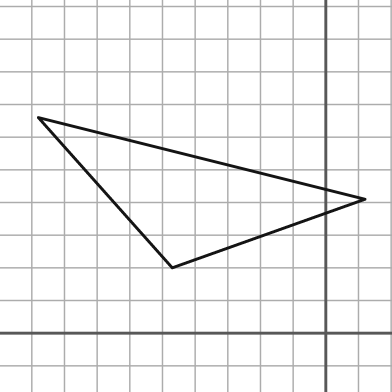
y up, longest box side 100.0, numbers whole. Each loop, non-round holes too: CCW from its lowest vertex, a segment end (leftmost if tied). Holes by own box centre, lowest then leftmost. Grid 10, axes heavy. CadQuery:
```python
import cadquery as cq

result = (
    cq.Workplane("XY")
    .moveTo(-47.0, 20.0)
    .lineTo(12.0, 41.0)
    .lineTo(-88.0, 66.0)
    .close()
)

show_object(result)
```